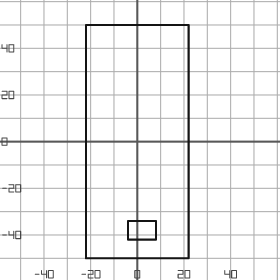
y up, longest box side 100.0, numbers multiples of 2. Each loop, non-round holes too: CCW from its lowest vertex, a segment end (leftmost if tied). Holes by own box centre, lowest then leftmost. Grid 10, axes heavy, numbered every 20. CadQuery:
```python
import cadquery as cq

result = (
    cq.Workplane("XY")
    .moveTo(-22.0, -50.0)
    .lineTo(22.0, -50.0)
    .lineTo(22.0, 50.0)
    .lineTo(-22.0, 50.0)
    .close()
    .moveTo(-4.0, -42.0)
    .lineTo(8.0, -42.0)
    .lineTo(8.0, -34.0)
    .lineTo(-4.0, -34.0)
    .close()
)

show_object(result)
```